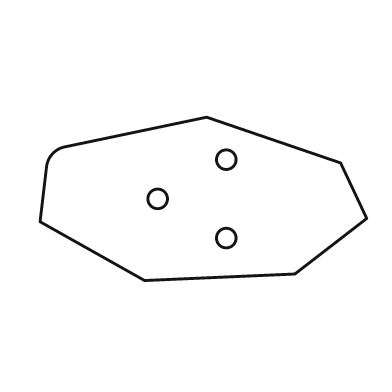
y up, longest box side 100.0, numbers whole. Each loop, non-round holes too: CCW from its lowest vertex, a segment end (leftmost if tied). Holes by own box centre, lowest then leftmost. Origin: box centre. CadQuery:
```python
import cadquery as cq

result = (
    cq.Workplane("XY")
    .moveTo(-18.0, -25.0)
    .lineTo(28.0, -23.0)
    .lineTo(50.0, -6.0)
    .lineTo(42.0, 11.0)
    .lineTo(1.0, 25.0)
    .lineTo(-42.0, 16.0)
    .threePointArc((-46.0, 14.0), (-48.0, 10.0))
    .lineTo(-50.0, -7.0)
    .close()
    .moveTo(7.0, -12.0)
    .circle(3.0)
    .moveTo(-14.0, 0.0)
    .circle(3.0)
    .moveTo(7.0, 12.0)
    .circle(3.0)
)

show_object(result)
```